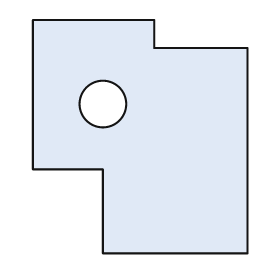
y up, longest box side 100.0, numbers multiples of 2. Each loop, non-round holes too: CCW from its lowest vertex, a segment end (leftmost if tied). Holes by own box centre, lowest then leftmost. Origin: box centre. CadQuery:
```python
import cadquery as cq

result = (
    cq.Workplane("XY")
    .moveTo(-16.0, -50.0)
    .lineTo(46.0, -50.0)
    .lineTo(46.0, 38.0)
    .lineTo(6.0, 38.0)
    .lineTo(6.0, 50.0)
    .lineTo(-46.0, 50.0)
    .lineTo(-46.0, -14.0)
    .lineTo(-16.0, -14.0)
    .close()
    .moveTo(-16.0, 14.0)
    .circle(10.0)
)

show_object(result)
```